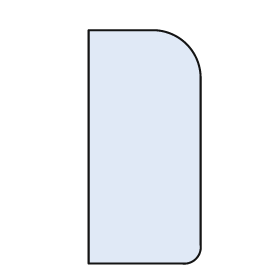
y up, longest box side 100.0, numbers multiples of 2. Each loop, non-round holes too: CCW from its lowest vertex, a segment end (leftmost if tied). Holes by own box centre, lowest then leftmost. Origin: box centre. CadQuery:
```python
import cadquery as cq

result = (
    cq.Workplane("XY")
    .moveTo(-24.0, -50.0)
    .lineTo(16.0, -50.0)
    .threePointArc((22.0, -48.0), (24.0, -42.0))
    .lineTo(24.0, 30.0)
    .threePointArc((18.0, 44.0), (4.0, 50.0))
    .lineTo(-24.0, 50.0)
    .close()
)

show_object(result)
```